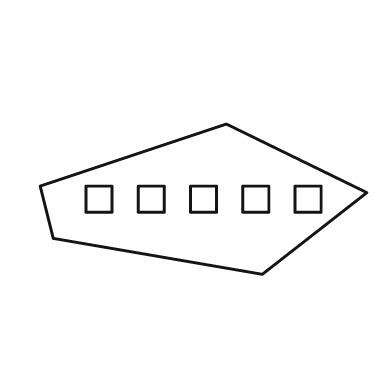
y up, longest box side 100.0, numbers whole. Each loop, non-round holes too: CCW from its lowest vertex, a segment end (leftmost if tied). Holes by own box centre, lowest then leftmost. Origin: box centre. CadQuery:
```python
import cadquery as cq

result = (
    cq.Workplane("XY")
    .moveTo(18.0, -23.0)
    .lineTo(50.0, 2.0)
    .lineTo(7.0, 23.0)
    .lineTo(-50.0, 4.0)
    .lineTo(-46.0, -12.0)
    .close()
    .moveTo(-36.0, -4.0)
    .lineTo(-28.0, -4.0)
    .lineTo(-28.0, 4.0)
    .lineTo(-36.0, 4.0)
    .close()
    .moveTo(-20.0, -4.0)
    .lineTo(-12.0, -4.0)
    .lineTo(-12.0, 4.0)
    .lineTo(-20.0, 4.0)
    .close()
    .moveTo(-4.0, -4.0)
    .lineTo(4.0, -4.0)
    .lineTo(4.0, 4.0)
    .lineTo(-4.0, 4.0)
    .close()
    .moveTo(12.0, -4.0)
    .lineTo(20.0, -4.0)
    .lineTo(20.0, 4.0)
    .lineTo(12.0, 4.0)
    .close()
    .moveTo(28.0, -4.0)
    .lineTo(36.0, -4.0)
    .lineTo(36.0, 4.0)
    .lineTo(28.0, 4.0)
    .close()
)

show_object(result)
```